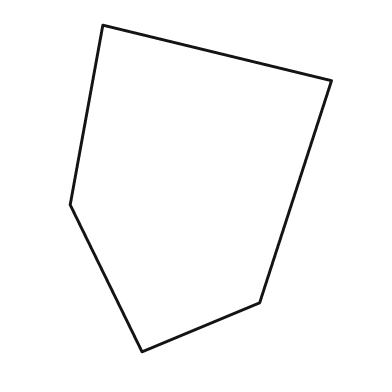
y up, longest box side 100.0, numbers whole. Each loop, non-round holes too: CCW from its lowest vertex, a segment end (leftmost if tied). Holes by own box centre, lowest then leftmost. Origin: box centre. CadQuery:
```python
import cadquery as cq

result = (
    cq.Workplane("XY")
    .moveTo(-18.0, -50.0)
    .lineTo(18.0, -35.0)
    .lineTo(40.0, 33.0)
    .lineTo(-30.0, 50.0)
    .lineTo(-40.0, -5.0)
    .close()
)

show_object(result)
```